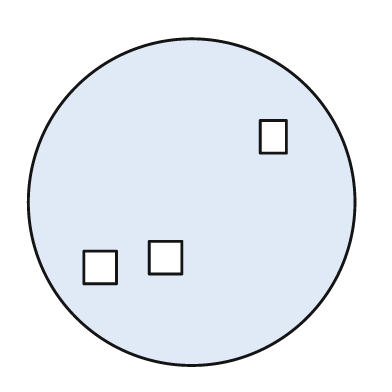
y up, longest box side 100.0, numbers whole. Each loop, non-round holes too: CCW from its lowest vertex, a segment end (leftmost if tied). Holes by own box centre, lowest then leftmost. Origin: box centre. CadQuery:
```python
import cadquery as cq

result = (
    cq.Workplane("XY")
    .moveTo(0.0, 0.0)
    .circle(50.0)
    .moveTo(-33.0, -25.0)
    .lineTo(-23.0, -25.0)
    .lineTo(-23.0, -15.0)
    .lineTo(-33.0, -15.0)
    .close()
    .moveTo(-13.0, -22.0)
    .lineTo(-3.0, -22.0)
    .lineTo(-3.0, -12.0)
    .lineTo(-13.0, -12.0)
    .close()
    .moveTo(21.0, 15.0)
    .lineTo(29.0, 15.0)
    .lineTo(29.0, 25.0)
    .lineTo(21.0, 25.0)
    .close()
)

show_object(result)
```